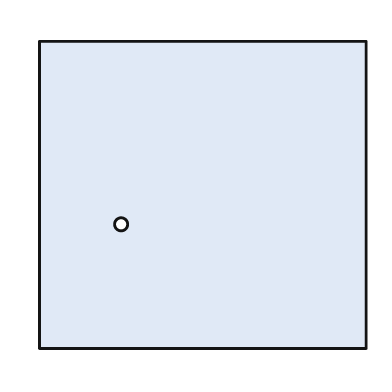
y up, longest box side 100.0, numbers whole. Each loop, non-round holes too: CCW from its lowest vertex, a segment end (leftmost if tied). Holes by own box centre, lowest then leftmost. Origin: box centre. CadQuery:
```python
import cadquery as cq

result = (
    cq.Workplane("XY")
    .moveTo(-50.0, -47.0)
    .lineTo(50.0, -47.0)
    .lineTo(50.0, 47.0)
    .lineTo(-50.0, 47.0)
    .close()
    .moveTo(-25.0, -9.0)
    .circle(2.0)
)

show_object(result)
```